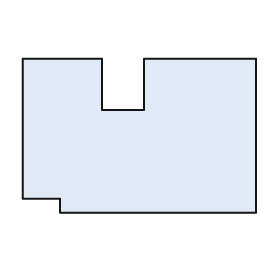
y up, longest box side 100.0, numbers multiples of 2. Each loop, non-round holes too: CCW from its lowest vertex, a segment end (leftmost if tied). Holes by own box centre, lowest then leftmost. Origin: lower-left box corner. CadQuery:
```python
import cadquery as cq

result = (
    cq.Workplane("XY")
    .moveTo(16.0, 0.0)
    .lineTo(100.0, 0.0)
    .lineTo(100.0, 66.0)
    .lineTo(52.0, 66.0)
    .lineTo(52.0, 44.0)
    .lineTo(34.0, 44.0)
    .lineTo(34.0, 66.0)
    .lineTo(0.0, 66.0)
    .lineTo(0.0, 6.0)
    .lineTo(16.0, 6.0)
    .close()
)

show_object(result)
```